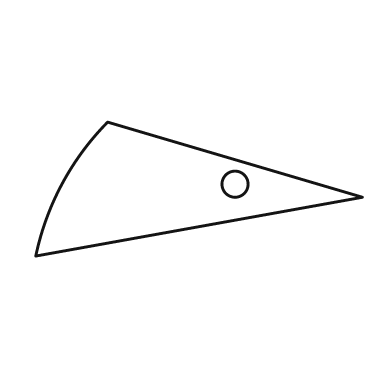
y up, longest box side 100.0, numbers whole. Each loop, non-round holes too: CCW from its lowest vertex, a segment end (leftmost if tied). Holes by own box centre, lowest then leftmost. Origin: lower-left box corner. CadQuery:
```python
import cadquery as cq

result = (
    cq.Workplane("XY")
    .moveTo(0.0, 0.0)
    .lineTo(100.0, 18.0)
    .lineTo(22.0, 41.0)
    .threePointArc((8.0, 22.0), (0.0, 0.0))
    .close()
    .moveTo(61.0, 22.0)
    .circle(4.0)
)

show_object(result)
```